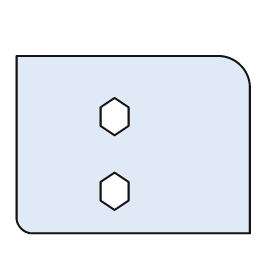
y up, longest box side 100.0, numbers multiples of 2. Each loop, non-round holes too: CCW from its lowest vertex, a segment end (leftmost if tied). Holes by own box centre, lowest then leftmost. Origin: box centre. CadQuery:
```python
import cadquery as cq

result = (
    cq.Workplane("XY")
    .moveTo(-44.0, -38.0)
    .lineTo(50.0, -38.0)
    .lineTo(50.0, 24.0)
    .threePointArc((46.0, 34.0), (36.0, 38.0))
    .lineTo(-50.0, 38.0)
    .lineTo(-50.0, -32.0)
    .threePointArc((-48.0, -36.0), (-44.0, -38.0))
    .close()
    .moveTo(-8.0, -28.0)
    .lineTo(-2.0, -24.0)
    .lineTo(-2.0, -16.0)
    .lineTo(-8.0, -12.0)
    .lineTo(-14.0, -16.0)
    .lineTo(-14.0, -24.0)
    .close()
    .moveTo(-8.0, 4.0)
    .lineTo(-2.0, 8.0)
    .lineTo(-2.0, 16.0)
    .lineTo(-8.0, 20.0)
    .lineTo(-14.0, 16.0)
    .lineTo(-14.0, 8.0)
    .close()
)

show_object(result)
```